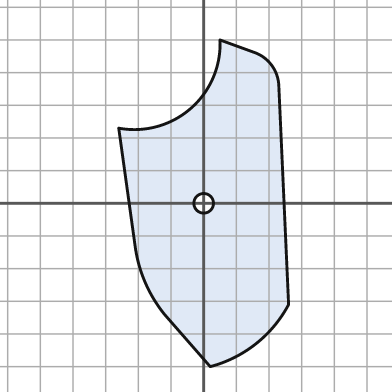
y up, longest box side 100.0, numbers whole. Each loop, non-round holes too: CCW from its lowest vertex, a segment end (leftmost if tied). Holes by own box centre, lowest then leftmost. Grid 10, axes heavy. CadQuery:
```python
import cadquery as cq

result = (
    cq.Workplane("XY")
    .moveTo(2.0, -50.0)
    .threePointArc((16.0, -43.0), (26.0, -31.0))
    .lineTo(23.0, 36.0)
    .threePointArc((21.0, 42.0), (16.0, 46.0))
    .lineTo(5.0, 50.0)
    .threePointArc((-4.0, 29.0), (-26.0, 23.0))
    .lineTo(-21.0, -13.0)
    .threePointArc((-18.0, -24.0), (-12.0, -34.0))
    .close()
    .moveTo(0.0, 0.0)
    .circle(3.0)
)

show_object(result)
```